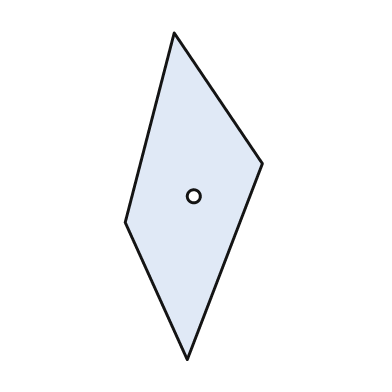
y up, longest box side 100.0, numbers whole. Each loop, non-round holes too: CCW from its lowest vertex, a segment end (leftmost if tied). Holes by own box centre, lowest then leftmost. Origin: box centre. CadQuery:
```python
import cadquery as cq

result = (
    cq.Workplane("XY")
    .moveTo(-2.0, -50.0)
    .lineTo(21.0, 10.0)
    .lineTo(-6.0, 50.0)
    .lineTo(-21.0, -8.0)
    .close()
    .moveTo(0.0, 0.0)
    .circle(2.0)
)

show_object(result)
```